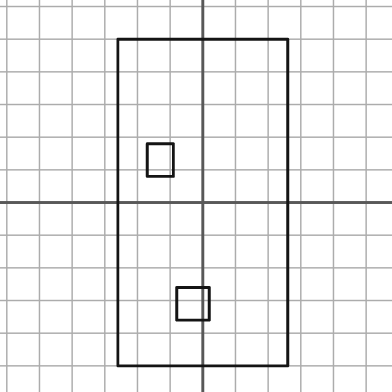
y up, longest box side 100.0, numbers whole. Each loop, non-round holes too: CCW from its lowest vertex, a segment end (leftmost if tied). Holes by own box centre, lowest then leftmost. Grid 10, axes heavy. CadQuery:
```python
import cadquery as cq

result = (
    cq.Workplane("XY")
    .moveTo(-26.0, -50.0)
    .lineTo(26.0, -50.0)
    .lineTo(26.0, 50.0)
    .lineTo(-26.0, 50.0)
    .close()
    .moveTo(-8.0, -36.0)
    .lineTo(2.0, -36.0)
    .lineTo(2.0, -26.0)
    .lineTo(-8.0, -26.0)
    .close()
    .moveTo(-17.0, 8.0)
    .lineTo(-9.0, 8.0)
    .lineTo(-9.0, 18.0)
    .lineTo(-17.0, 18.0)
    .close()
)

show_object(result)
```